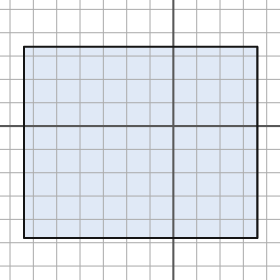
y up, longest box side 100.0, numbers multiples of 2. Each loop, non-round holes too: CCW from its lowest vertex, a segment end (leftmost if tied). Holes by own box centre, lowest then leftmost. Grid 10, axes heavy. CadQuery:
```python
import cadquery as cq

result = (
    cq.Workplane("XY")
    .moveTo(-64.0, -48.0)
    .lineTo(36.0, -48.0)
    .lineTo(36.0, 34.0)
    .lineTo(-64.0, 34.0)
    .close()
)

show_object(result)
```